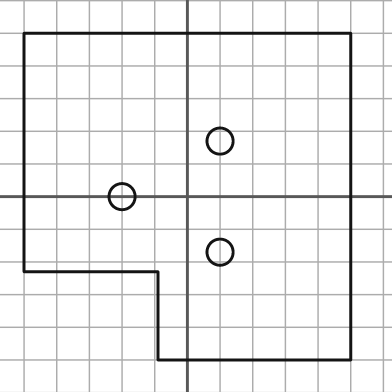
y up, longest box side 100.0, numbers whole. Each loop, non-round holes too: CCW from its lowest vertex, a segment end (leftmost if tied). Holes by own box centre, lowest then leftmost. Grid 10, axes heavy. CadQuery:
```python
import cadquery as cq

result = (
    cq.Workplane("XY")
    .moveTo(-9.0, -50.0)
    .lineTo(50.0, -50.0)
    .lineTo(50.0, 50.0)
    .lineTo(-50.0, 50.0)
    .lineTo(-50.0, -23.0)
    .lineTo(-9.0, -23.0)
    .close()
    .moveTo(10.0, -17.0)
    .circle(4.0)
    .moveTo(-20.0, 0.0)
    .circle(4.0)
    .moveTo(10.0, 17.0)
    .circle(4.0)
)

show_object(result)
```